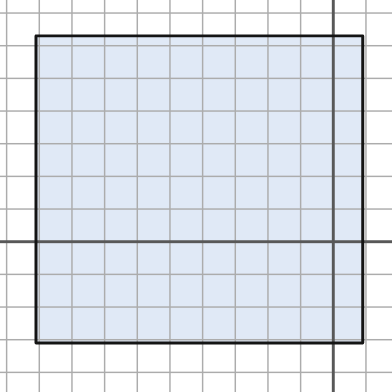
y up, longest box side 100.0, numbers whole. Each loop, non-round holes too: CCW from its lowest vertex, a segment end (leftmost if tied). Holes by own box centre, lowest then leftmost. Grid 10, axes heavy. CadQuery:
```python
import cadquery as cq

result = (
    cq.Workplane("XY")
    .moveTo(-91.0, -31.0)
    .lineTo(9.0, -31.0)
    .lineTo(9.0, 63.0)
    .lineTo(-91.0, 63.0)
    .close()
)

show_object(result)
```